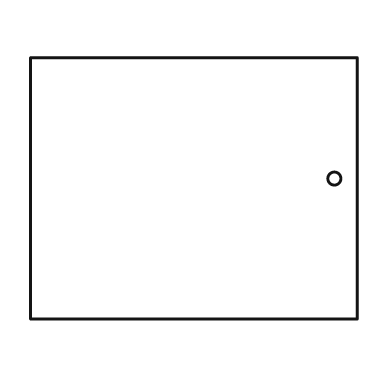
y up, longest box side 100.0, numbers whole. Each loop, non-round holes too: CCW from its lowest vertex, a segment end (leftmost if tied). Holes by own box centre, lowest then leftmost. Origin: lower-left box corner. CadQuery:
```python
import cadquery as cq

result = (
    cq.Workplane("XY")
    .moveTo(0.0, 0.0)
    .lineTo(100.0, 0.0)
    .lineTo(100.0, 80.0)
    .lineTo(0.0, 80.0)
    .close()
    .moveTo(93.0, 43.0)
    .circle(2.0)
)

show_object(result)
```